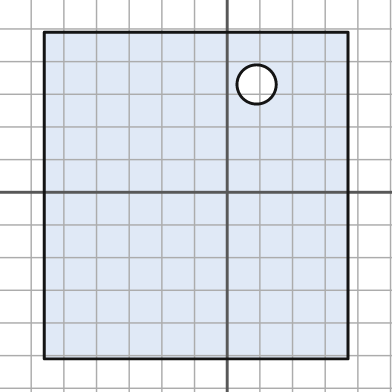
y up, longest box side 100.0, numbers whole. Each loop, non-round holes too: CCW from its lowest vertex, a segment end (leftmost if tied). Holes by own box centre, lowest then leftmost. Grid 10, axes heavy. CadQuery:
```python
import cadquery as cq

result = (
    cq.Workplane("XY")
    .moveTo(-56.0, -51.0)
    .lineTo(37.0, -51.0)
    .lineTo(37.0, 49.0)
    .lineTo(-56.0, 49.0)
    .close()
    .moveTo(9.0, 33.0)
    .circle(6.0)
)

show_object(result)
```